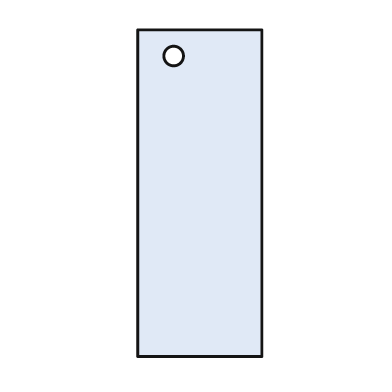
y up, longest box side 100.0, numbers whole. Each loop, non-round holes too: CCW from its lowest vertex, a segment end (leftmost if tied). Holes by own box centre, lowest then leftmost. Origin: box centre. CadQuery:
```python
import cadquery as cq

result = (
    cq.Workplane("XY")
    .moveTo(-19.0, -50.0)
    .lineTo(19.0, -50.0)
    .lineTo(19.0, 50.0)
    .lineTo(-19.0, 50.0)
    .close()
    .moveTo(-8.0, 42.0)
    .circle(3.0)
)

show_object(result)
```